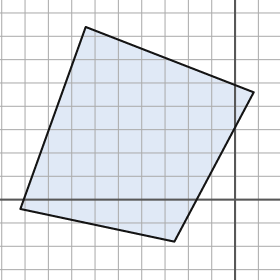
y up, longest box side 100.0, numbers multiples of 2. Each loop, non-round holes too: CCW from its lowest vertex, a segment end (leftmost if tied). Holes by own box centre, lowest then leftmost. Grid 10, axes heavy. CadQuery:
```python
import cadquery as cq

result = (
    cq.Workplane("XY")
    .moveTo(-26.0, -18.0)
    .lineTo(8.0, 46.0)
    .lineTo(-64.0, 74.0)
    .lineTo(-92.0, -4.0)
    .close()
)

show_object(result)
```